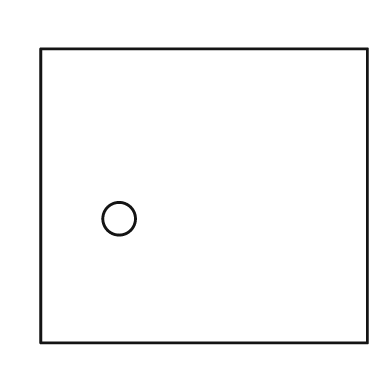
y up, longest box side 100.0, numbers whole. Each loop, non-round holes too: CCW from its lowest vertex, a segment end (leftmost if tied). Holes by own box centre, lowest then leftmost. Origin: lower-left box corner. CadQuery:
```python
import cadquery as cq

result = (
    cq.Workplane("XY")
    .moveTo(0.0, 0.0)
    .lineTo(100.0, 0.0)
    .lineTo(100.0, 90.0)
    .lineTo(0.0, 90.0)
    .close()
    .moveTo(24.0, 38.0)
    .circle(5.0)
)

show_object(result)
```